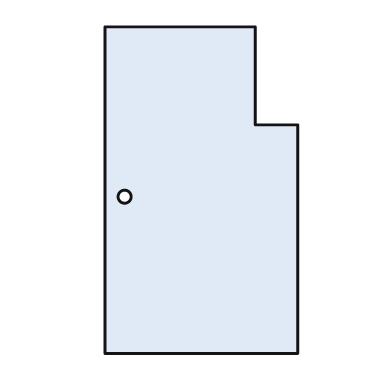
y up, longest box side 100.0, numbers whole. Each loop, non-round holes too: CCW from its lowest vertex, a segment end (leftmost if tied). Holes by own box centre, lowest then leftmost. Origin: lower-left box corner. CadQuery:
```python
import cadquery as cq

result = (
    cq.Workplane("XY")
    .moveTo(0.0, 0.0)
    .lineTo(59.0, 0.0)
    .lineTo(59.0, 70.0)
    .lineTo(46.0, 70.0)
    .lineTo(46.0, 100.0)
    .lineTo(0.0, 100.0)
    .close()
    .moveTo(6.0, 48.0)
    .circle(2.0)
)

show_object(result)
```